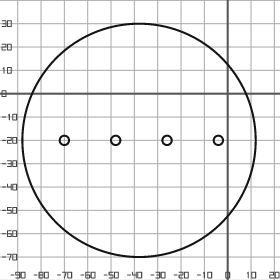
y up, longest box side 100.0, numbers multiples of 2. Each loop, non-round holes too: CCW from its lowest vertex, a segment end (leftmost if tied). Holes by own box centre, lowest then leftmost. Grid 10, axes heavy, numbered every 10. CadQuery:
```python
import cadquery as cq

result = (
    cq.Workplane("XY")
    .moveTo(-38.0, -20.0)
    .circle(50.0)
    .moveTo(-70.0, -20.0)
    .circle(2.0)
    .moveTo(-48.0, -20.0)
    .circle(2.0)
    .moveTo(-26.0, -20.0)
    .circle(2.0)
    .moveTo(-4.0, -20.0)
    .circle(2.0)
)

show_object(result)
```